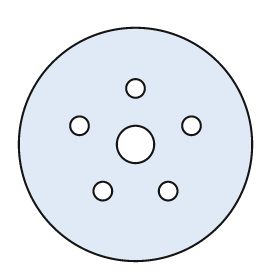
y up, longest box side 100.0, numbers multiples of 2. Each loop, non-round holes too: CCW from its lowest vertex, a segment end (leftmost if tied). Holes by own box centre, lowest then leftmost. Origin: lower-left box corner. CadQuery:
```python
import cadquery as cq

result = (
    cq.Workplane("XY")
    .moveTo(50.0, 50.0)
    .circle(50.0)
    .moveTo(36.0, 30.0)
    .circle(4.0)
    .moveTo(64.0, 30.0)
    .circle(4.0)
    .moveTo(50.0, 50.0)
    .circle(8.0)
    .moveTo(26.0, 58.0)
    .circle(4.0)
    .moveTo(74.0, 58.0)
    .circle(4.0)
    .moveTo(50.0, 74.0)
    .circle(4.0)
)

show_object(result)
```